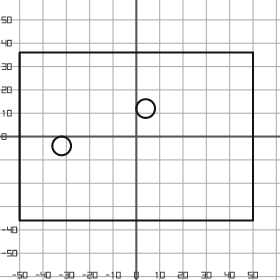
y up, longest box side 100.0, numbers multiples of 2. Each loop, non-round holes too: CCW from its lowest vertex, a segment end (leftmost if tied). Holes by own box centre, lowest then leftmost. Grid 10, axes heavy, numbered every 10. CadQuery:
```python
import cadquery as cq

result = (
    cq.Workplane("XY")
    .moveTo(-50.0, -36.0)
    .lineTo(50.0, -36.0)
    .lineTo(50.0, 36.0)
    .lineTo(-50.0, 36.0)
    .close()
    .moveTo(-32.0, -4.0)
    .circle(4.0)
    .moveTo(4.0, 12.0)
    .circle(4.0)
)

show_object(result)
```